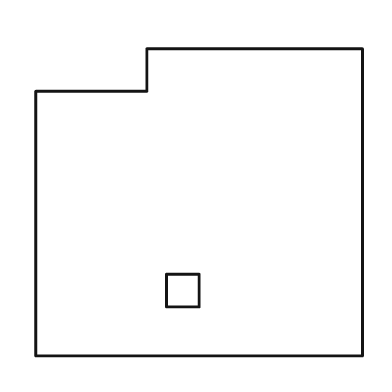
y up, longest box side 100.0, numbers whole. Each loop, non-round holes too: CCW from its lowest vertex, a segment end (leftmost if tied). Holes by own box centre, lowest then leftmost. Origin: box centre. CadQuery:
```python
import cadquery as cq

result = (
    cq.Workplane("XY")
    .moveTo(-50.0, -47.0)
    .lineTo(50.0, -47.0)
    .lineTo(50.0, 47.0)
    .lineTo(-16.0, 47.0)
    .lineTo(-16.0, 34.0)
    .lineTo(-50.0, 34.0)
    .close()
    .moveTo(-10.0, -32.0)
    .lineTo(0.0, -32.0)
    .lineTo(0.0, -22.0)
    .lineTo(-10.0, -22.0)
    .close()
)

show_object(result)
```